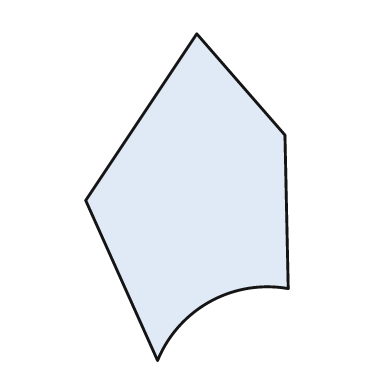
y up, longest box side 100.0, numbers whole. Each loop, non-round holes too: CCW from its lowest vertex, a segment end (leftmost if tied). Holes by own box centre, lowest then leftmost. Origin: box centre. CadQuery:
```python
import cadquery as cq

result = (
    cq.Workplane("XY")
    .moveTo(-9.0, -50.0)
    .threePointArc((7.0, -32.0), (31.0, -28.0))
    .lineTo(30.0, 19.0)
    .lineTo(3.0, 50.0)
    .lineTo(-31.0, -1.0)
    .close()
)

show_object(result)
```